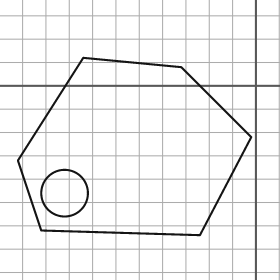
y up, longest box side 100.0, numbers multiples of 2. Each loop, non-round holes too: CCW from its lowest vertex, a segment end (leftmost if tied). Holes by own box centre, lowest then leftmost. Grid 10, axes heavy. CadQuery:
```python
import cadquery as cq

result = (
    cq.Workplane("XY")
    .moveTo(-24.0, -64.0)
    .lineTo(-2.0, -22.0)
    .lineTo(-32.0, 8.0)
    .lineTo(-74.0, 12.0)
    .lineTo(-102.0, -32.0)
    .lineTo(-92.0, -62.0)
    .close()
    .moveTo(-82.0, -46.0)
    .circle(10.0)
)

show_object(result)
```